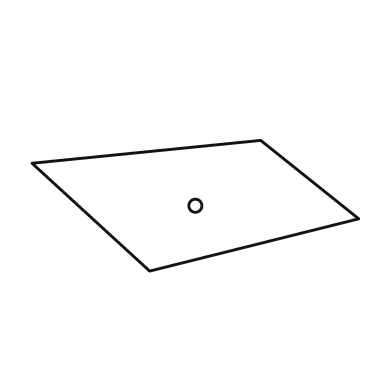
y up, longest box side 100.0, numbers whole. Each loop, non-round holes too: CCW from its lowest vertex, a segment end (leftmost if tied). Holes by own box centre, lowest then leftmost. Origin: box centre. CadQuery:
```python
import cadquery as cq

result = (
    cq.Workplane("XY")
    .moveTo(-14.0, -20.0)
    .lineTo(50.0, -4.0)
    .lineTo(20.0, 20.0)
    .lineTo(-50.0, 13.0)
    .close()
    .moveTo(0.0, 0.0)
    .circle(2.0)
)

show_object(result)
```